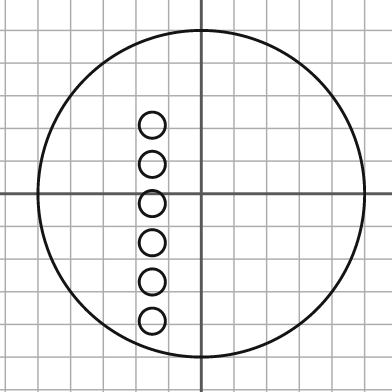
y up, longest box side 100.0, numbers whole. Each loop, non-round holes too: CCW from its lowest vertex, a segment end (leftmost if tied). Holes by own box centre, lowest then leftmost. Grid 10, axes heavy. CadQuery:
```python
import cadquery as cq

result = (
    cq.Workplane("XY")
    .moveTo(0.0, 0.0)
    .circle(50.0)
    .moveTo(-15.0, -39.0)
    .circle(4.0)
    .moveTo(-15.0, -27.0)
    .circle(4.0)
    .moveTo(-15.0, -15.0)
    .circle(4.0)
    .moveTo(-15.0, -3.0)
    .circle(4.0)
    .moveTo(-15.0, 9.0)
    .circle(4.0)
    .moveTo(-15.0, 21.0)
    .circle(4.0)
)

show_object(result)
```